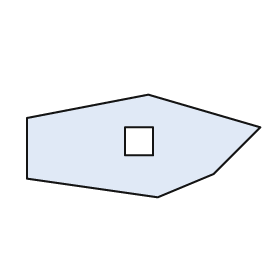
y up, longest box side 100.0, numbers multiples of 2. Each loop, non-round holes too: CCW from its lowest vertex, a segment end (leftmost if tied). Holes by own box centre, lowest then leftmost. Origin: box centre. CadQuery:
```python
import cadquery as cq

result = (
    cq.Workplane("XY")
    .moveTo(6.0, -22.0)
    .lineTo(30.0, -12.0)
    .lineTo(50.0, 8.0)
    .lineTo(2.0, 22.0)
    .lineTo(-50.0, 12.0)
    .lineTo(-50.0, -14.0)
    .close()
    .moveTo(-8.0, -4.0)
    .lineTo(4.0, -4.0)
    .lineTo(4.0, 8.0)
    .lineTo(-8.0, 8.0)
    .close()
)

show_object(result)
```